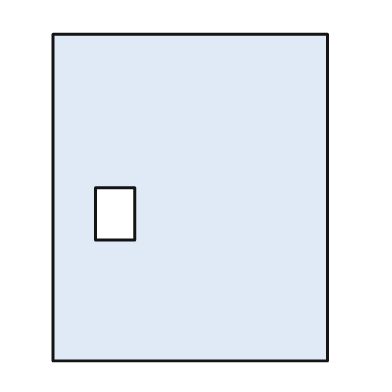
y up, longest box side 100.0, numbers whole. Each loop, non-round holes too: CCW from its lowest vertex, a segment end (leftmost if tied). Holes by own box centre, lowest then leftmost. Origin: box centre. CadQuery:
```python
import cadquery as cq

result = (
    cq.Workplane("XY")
    .moveTo(-42.0, -50.0)
    .lineTo(42.0, -50.0)
    .lineTo(42.0, 50.0)
    .lineTo(-42.0, 50.0)
    .close()
    .moveTo(-29.0, -13.0)
    .lineTo(-17.0, -13.0)
    .lineTo(-17.0, 3.0)
    .lineTo(-29.0, 3.0)
    .close()
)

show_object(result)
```